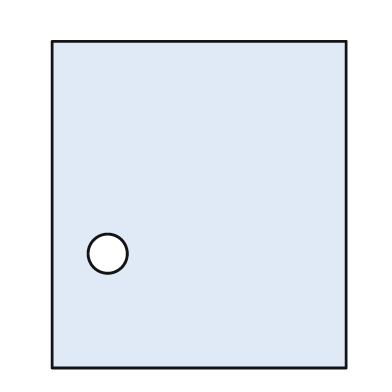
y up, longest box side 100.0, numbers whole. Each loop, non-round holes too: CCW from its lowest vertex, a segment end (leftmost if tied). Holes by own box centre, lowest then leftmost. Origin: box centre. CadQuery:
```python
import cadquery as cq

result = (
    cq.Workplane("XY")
    .moveTo(-45.0, -50.0)
    .lineTo(45.0, -50.0)
    .lineTo(45.0, 50.0)
    .lineTo(-45.0, 50.0)
    .close()
    .moveTo(-28.0, -15.0)
    .circle(6.0)
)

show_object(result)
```